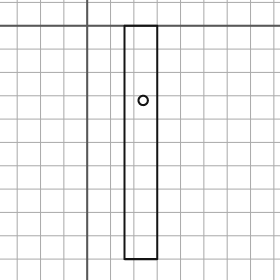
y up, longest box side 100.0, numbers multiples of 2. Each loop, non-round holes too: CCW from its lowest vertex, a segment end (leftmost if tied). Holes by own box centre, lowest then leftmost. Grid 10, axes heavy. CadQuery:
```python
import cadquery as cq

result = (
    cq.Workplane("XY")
    .moveTo(16.0, -100.0)
    .lineTo(30.0, -100.0)
    .lineTo(30.0, 0.0)
    .lineTo(16.0, 0.0)
    .close()
    .moveTo(24.0, -32.0)
    .circle(2.0)
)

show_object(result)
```